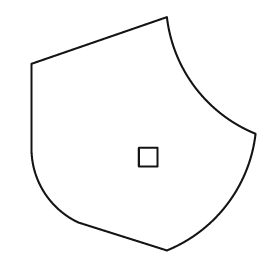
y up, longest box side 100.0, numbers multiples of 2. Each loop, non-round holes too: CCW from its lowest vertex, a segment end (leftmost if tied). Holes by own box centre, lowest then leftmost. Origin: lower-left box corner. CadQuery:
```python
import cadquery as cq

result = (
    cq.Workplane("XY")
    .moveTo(58.0, 0.0)
    .threePointArc((84.0, 20.0), (96.0, 50.0))
    .threePointArc((70.0, 70.0), (58.0, 100.0))
    .lineTo(0.0, 80.0)
    .lineTo(0.0, 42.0)
    .threePointArc((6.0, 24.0), (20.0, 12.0))
    .close()
    .moveTo(46.0, 36.0)
    .lineTo(54.0, 36.0)
    .lineTo(54.0, 44.0)
    .lineTo(46.0, 44.0)
    .close()
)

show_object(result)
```